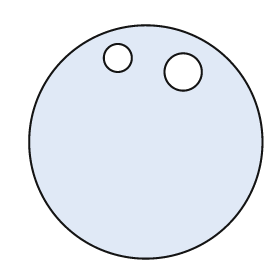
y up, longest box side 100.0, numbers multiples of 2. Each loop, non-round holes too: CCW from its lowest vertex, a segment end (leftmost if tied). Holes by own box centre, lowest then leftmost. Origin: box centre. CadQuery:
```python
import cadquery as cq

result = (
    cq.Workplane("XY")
    .moveTo(0.0, 0.0)
    .circle(50.0)
    .moveTo(16.0, 30.0)
    .circle(8.0)
    .moveTo(-12.0, 36.0)
    .circle(6.0)
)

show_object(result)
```